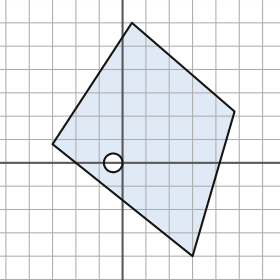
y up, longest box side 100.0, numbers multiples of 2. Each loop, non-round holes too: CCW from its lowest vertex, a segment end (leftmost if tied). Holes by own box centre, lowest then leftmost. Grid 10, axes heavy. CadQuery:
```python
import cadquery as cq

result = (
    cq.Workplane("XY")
    .moveTo(30.0, -40.0)
    .lineTo(48.0, 22.0)
    .lineTo(4.0, 60.0)
    .lineTo(-30.0, 8.0)
    .close()
    .moveTo(-4.0, 0.0)
    .circle(4.0)
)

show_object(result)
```